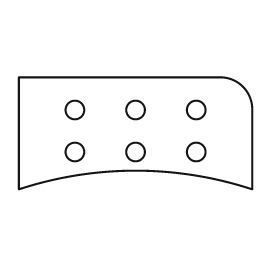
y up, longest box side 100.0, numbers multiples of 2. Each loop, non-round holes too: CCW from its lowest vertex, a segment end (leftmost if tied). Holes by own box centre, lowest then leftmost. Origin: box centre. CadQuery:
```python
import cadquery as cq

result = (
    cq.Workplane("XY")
    .moveTo(-50.0, -24.0)
    .threePointArc((0.0, -16.0), (50.0, -24.0))
    .lineTo(50.0, 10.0)
    .threePointArc((46.0, 20.0), (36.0, 24.0))
    .lineTo(-50.0, 24.0)
    .close()
    .moveTo(-26.0, -8.0)
    .circle(4.0)
    .moveTo(0.0, -8.0)
    .circle(4.0)
    .moveTo(26.0, -8.0)
    .circle(4.0)
    .moveTo(-26.0, 10.0)
    .circle(4.0)
    .moveTo(0.0, 10.0)
    .circle(4.0)
    .moveTo(26.0, 10.0)
    .circle(4.0)
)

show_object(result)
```